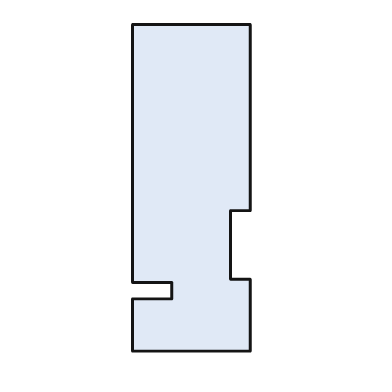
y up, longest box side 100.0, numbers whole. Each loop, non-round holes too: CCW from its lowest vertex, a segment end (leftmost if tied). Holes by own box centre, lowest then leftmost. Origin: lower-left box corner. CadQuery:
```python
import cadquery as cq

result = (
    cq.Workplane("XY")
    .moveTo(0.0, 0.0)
    .lineTo(36.0, 0.0)
    .lineTo(36.0, 22.0)
    .lineTo(30.0, 22.0)
    .lineTo(30.0, 43.0)
    .lineTo(36.0, 43.0)
    .lineTo(36.0, 100.0)
    .lineTo(0.0, 100.0)
    .lineTo(0.0, 21.0)
    .lineTo(12.0, 21.0)
    .lineTo(12.0, 16.0)
    .lineTo(0.0, 16.0)
    .close()
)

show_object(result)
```